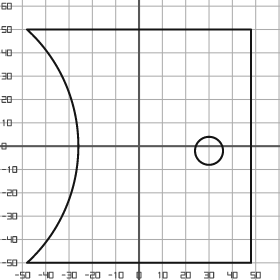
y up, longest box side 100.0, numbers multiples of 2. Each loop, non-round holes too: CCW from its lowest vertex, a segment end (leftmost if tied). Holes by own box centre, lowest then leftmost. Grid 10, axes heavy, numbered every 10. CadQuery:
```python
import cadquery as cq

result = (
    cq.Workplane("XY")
    .moveTo(-48.0, -50.0)
    .lineTo(48.0, -50.0)
    .lineTo(48.0, 50.0)
    .lineTo(-48.0, 50.0)
    .threePointArc((-26.0, 0.0), (-48.0, -50.0))
    .close()
    .moveTo(30.0, -2.0)
    .circle(6.0)
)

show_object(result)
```